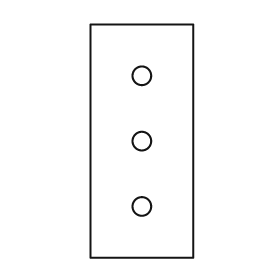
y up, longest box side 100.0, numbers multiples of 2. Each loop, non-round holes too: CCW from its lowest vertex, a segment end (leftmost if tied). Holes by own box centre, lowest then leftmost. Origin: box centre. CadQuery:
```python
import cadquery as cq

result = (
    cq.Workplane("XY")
    .moveTo(-22.0, -50.0)
    .lineTo(22.0, -50.0)
    .lineTo(22.0, 50.0)
    .lineTo(-22.0, 50.0)
    .close()
    .moveTo(0.0, -28.0)
    .circle(4.0)
    .moveTo(0.0, 0.0)
    .circle(4.0)
    .moveTo(0.0, 28.0)
    .circle(4.0)
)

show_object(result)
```